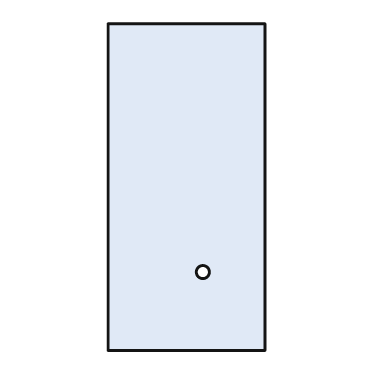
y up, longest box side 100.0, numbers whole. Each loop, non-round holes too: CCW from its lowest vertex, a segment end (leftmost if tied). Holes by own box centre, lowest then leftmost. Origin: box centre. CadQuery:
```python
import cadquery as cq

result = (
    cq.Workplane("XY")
    .moveTo(-24.0, -50.0)
    .lineTo(24.0, -50.0)
    .lineTo(24.0, 50.0)
    .lineTo(-24.0, 50.0)
    .close()
    .moveTo(5.0, -26.0)
    .circle(2.0)
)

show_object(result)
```